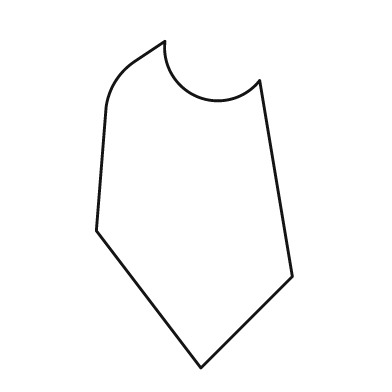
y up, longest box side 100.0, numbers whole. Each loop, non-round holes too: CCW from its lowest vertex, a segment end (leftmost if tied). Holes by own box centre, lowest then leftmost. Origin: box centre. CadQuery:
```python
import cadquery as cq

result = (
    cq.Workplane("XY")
    .moveTo(2.0, -50.0)
    .lineTo(30.0, -22.0)
    .lineTo(20.0, 38.0)
    .threePointArc((1.0, 33.0), (-9.0, 50.0))
    .lineTo(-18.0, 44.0)
    .threePointArc((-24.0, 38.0), (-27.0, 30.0))
    .lineTo(-30.0, -8.0)
    .close()
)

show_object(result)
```